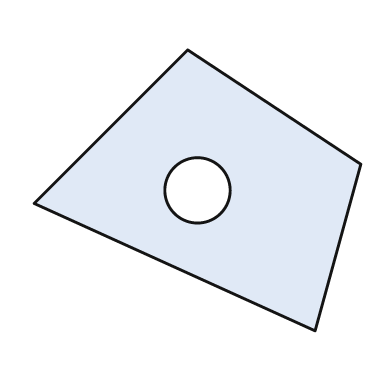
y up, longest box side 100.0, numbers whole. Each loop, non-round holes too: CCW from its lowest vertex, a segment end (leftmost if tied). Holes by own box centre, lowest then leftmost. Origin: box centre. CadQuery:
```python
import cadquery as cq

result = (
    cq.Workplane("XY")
    .moveTo(36.0, -43.0)
    .lineTo(50.0, 8.0)
    .lineTo(-3.0, 43.0)
    .lineTo(-50.0, -4.0)
    .close()
    .moveTo(0.0, 0.0)
    .circle(10.0)
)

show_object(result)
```